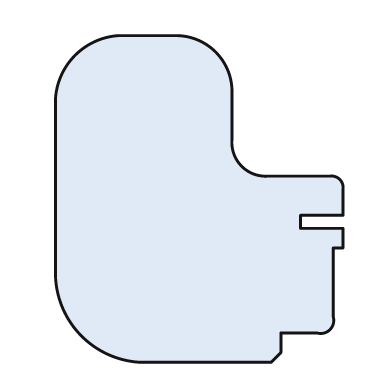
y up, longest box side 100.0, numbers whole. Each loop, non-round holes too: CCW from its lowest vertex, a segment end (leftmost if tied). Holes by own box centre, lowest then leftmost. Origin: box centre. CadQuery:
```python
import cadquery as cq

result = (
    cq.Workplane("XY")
    .moveTo(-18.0, -50.0)
    .lineTo(22.0, -50.0)
    .lineTo(25.0, -47.0)
    .lineTo(25.0, -41.0)
    .lineTo(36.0, -41.0)
    .threePointArc((40.0, -40.0), (41.0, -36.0))
    .lineTo(41.0, -15.0)
    .lineTo(44.0, -15.0)
    .lineTo(44.0, -9.0)
    .lineTo(31.0, -9.0)
    .lineTo(31.0, -5.0)
    .lineTo(44.0, -5.0)
    .lineTo(44.0, 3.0)
    .threePointArc((43.0, 6.0), (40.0, 7.0))
    .lineTo(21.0, 7.0)
    .threePointArc((13.0, 10.0), (10.0, 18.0))
    .lineTo(10.0, 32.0)
    .threePointArc((5.0, 45.0), (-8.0, 50.0))
    .lineTo(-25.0, 50.0)
    .threePointArc((-38.0, 44.0), (-44.0, 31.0))
    .lineTo(-44.0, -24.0)
    .threePointArc((-36.0, -42.0), (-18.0, -50.0))
    .close()
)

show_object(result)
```